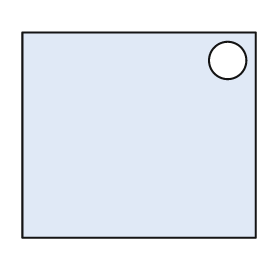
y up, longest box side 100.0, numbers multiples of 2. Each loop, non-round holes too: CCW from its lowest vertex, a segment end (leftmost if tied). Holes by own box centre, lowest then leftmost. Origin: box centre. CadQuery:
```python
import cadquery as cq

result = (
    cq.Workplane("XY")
    .moveTo(-50.0, -44.0)
    .lineTo(50.0, -44.0)
    .lineTo(50.0, 44.0)
    .lineTo(-50.0, 44.0)
    .close()
    .moveTo(38.0, 32.0)
    .circle(8.0)
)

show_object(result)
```